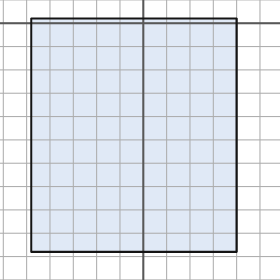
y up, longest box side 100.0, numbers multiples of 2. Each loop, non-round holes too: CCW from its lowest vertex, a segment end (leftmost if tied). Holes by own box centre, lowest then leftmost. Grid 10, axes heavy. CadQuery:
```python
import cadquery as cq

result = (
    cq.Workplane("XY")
    .moveTo(-48.0, -98.0)
    .lineTo(40.0, -98.0)
    .lineTo(40.0, 2.0)
    .lineTo(-48.0, 2.0)
    .close()
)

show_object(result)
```